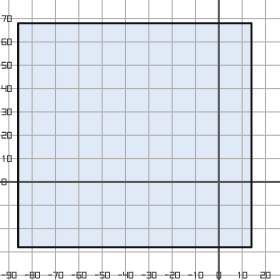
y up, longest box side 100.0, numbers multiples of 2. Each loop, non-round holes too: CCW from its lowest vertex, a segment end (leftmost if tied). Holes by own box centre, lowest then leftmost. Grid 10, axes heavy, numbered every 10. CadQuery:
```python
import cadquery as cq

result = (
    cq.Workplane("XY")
    .moveTo(-86.0, -28.0)
    .lineTo(14.0, -28.0)
    .lineTo(14.0, 68.0)
    .lineTo(-86.0, 68.0)
    .close()
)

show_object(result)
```